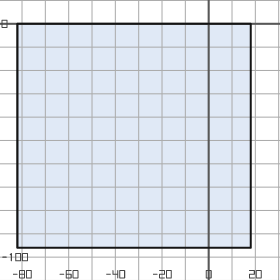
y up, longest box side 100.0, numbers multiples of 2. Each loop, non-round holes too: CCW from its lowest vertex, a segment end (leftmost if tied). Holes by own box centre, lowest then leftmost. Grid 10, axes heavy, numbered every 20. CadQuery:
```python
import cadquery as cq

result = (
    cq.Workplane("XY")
    .moveTo(-82.0, -96.0)
    .lineTo(18.0, -96.0)
    .lineTo(18.0, 0.0)
    .lineTo(-82.0, 0.0)
    .close()
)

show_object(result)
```